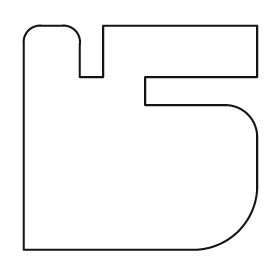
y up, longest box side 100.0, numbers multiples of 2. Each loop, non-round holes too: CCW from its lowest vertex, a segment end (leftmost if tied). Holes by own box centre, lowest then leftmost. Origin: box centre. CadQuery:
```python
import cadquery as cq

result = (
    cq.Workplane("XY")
    .moveTo(-50.0, -48.0)
    .lineTo(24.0, -48.0)
    .threePointArc((42.0, -40.0), (50.0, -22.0))
    .lineTo(50.0, 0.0)
    .threePointArc((46.0, 10.0), (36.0, 14.0))
    .lineTo(2.0, 14.0)
    .lineTo(2.0, 26.0)
    .lineTo(50.0, 26.0)
    .lineTo(50.0, 48.0)
    .lineTo(-16.0, 48.0)
    .lineTo(-16.0, 26.0)
    .lineTo(-26.0, 26.0)
    .lineTo(-26.0, 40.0)
    .threePointArc((-28.0, 46.0), (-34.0, 48.0))
    .lineTo(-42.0, 48.0)
    .threePointArc((-48.0, 46.0), (-50.0, 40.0))
    .close()
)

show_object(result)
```